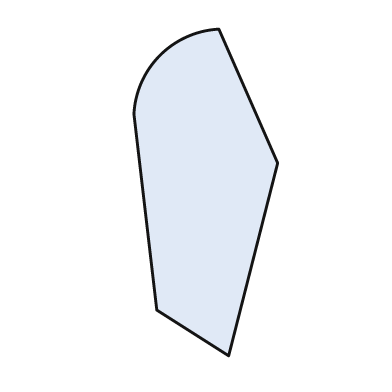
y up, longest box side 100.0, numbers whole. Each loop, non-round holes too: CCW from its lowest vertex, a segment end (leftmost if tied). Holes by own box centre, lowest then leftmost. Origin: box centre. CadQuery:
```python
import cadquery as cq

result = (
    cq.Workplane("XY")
    .moveTo(7.0, -50.0)
    .lineTo(22.0, 9.0)
    .lineTo(4.0, 50.0)
    .threePointArc((-14.0, 42.0), (-22.0, 24.0))
    .lineTo(-15.0, -36.0)
    .close()
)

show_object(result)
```